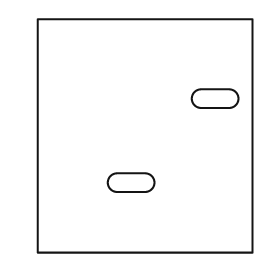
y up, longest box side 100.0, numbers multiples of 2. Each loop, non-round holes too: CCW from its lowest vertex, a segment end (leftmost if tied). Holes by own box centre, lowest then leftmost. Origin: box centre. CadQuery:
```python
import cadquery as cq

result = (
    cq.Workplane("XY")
    .moveTo(-46.0, -50.0)
    .lineTo(46.0, -50.0)
    .lineTo(46.0, 50.0)
    .lineTo(-46.0, 50.0)
    .close()
    .moveTo(-12.0, -24.0)
    .lineTo(0.0, -24.0)
    .threePointArc((4.0, -20.0), (0.0, -16.0))
    .lineTo(-12.0, -16.0)
    .threePointArc((-16.0, -20.0), (-12.0, -24.0))
    .close()
    .moveTo(24.0, 12.0)
    .lineTo(36.0, 12.0)
    .threePointArc((40.0, 16.0), (36.0, 20.0))
    .lineTo(24.0, 20.0)
    .threePointArc((20.0, 16.0), (24.0, 12.0))
    .close()
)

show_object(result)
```